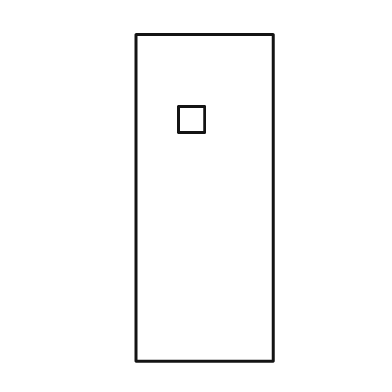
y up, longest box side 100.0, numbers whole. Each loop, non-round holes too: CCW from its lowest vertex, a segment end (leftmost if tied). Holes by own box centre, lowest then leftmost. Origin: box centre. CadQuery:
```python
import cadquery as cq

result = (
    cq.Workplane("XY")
    .moveTo(-21.0, -50.0)
    .lineTo(21.0, -50.0)
    .lineTo(21.0, 50.0)
    .lineTo(-21.0, 50.0)
    .close()
    .moveTo(-8.0, 20.0)
    .lineTo(0.0, 20.0)
    .lineTo(0.0, 28.0)
    .lineTo(-8.0, 28.0)
    .close()
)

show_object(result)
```